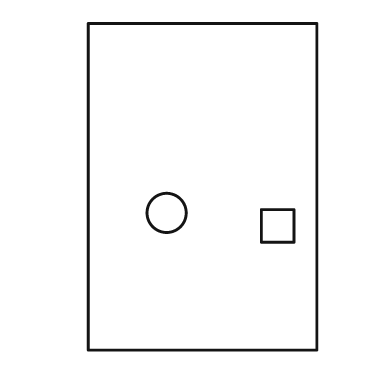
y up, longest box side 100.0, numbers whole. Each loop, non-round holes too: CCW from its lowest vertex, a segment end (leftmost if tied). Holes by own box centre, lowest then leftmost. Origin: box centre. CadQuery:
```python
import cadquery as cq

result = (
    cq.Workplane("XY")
    .moveTo(-35.0, -50.0)
    .lineTo(35.0, -50.0)
    .lineTo(35.0, 50.0)
    .lineTo(-35.0, 50.0)
    .close()
    .moveTo(18.0, -17.0)
    .lineTo(28.0, -17.0)
    .lineTo(28.0, -7.0)
    .lineTo(18.0, -7.0)
    .close()
    .moveTo(-11.0, -8.0)
    .circle(6.0)
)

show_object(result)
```